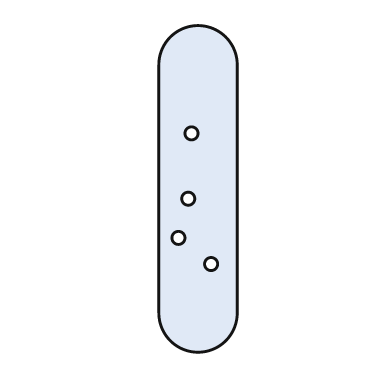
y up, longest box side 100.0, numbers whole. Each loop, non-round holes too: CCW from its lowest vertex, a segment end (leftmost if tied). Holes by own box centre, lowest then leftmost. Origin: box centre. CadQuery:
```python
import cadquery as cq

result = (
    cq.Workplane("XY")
    .moveTo(-12.0, -38.0)
    .threePointArc((0.0, -50.0), (12.0, -38.0))
    .lineTo(12.0, 38.0)
    .threePointArc((0.0, 50.0), (-12.0, 38.0))
    .close()
    .moveTo(4.0, -23.0)
    .circle(2.0)
    .moveTo(-6.0, -15.0)
    .circle(2.0)
    .moveTo(-3.0, -3.0)
    .circle(2.0)
    .moveTo(-2.0, 17.0)
    .circle(2.0)
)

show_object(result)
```